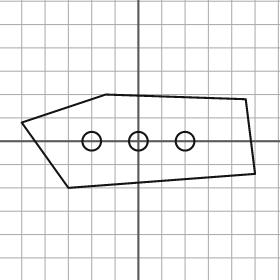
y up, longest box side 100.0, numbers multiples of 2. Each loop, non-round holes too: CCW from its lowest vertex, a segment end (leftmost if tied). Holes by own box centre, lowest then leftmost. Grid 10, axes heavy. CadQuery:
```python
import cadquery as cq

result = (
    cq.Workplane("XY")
    .moveTo(-30.0, -20.0)
    .lineTo(50.0, -14.0)
    .lineTo(46.0, 18.0)
    .lineTo(-14.0, 20.0)
    .lineTo(-50.0, 8.0)
    .close()
    .moveTo(-20.0, 0.0)
    .circle(4.0)
    .moveTo(0.0, 0.0)
    .circle(4.0)
    .moveTo(20.0, 0.0)
    .circle(4.0)
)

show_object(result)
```